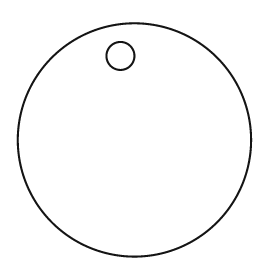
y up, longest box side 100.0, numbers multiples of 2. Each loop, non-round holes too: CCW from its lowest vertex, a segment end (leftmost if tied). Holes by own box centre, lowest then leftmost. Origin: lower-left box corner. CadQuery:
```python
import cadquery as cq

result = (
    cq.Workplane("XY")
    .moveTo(50.0, 50.0)
    .circle(50.0)
    .moveTo(44.0, 86.0)
    .circle(6.0)
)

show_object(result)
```